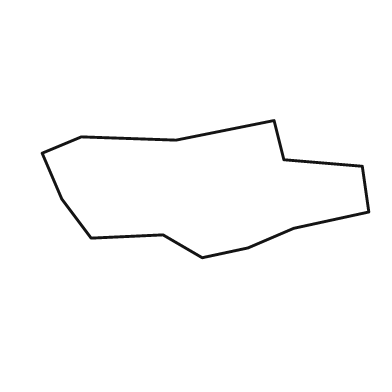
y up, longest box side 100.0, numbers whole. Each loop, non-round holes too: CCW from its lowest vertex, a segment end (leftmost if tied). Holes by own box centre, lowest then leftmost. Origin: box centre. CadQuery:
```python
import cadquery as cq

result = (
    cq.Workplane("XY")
    .moveTo(-1.0, -21.0)
    .lineTo(13.0, -18.0)
    .lineTo(27.0, -12.0)
    .lineTo(50.0, -7.0)
    .lineTo(48.0, 7.0)
    .lineTo(24.0, 9.0)
    .lineTo(21.0, 21.0)
    .lineTo(-9.0, 15.0)
    .lineTo(-38.0, 16.0)
    .lineTo(-50.0, 11.0)
    .lineTo(-44.0, -3.0)
    .lineTo(-35.0, -15.0)
    .lineTo(-13.0, -14.0)
    .close()
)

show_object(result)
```